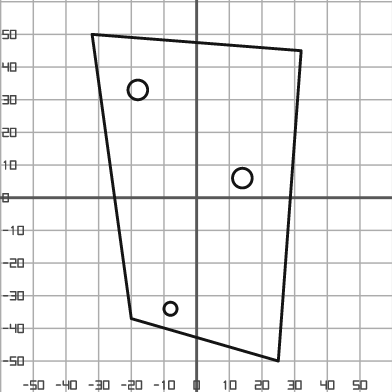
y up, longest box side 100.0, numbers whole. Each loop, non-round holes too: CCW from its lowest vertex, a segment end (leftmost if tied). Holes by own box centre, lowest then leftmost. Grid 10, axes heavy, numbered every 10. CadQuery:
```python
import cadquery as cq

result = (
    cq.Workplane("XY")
    .moveTo(25.0, -50.0)
    .lineTo(32.0, 45.0)
    .lineTo(-32.0, 50.0)
    .lineTo(-20.0, -37.0)
    .close()
    .moveTo(-8.0, -34.0)
    .circle(2.0)
    .moveTo(14.0, 6.0)
    .circle(3.0)
    .moveTo(-18.0, 33.0)
    .circle(3.0)
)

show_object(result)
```